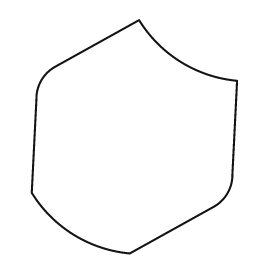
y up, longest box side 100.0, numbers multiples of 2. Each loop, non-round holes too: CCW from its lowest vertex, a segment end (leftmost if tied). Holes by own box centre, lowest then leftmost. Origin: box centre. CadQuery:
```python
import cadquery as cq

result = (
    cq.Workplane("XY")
    .moveTo(-2.0, -50.0)
    .lineTo(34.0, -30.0)
    .threePointArc((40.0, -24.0), (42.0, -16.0))
    .lineTo(44.0, 24.0)
    .threePointArc((20.0, 32.0), (2.0, 50.0))
    .lineTo(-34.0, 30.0)
    .threePointArc((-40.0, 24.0), (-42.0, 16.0))
    .lineTo(-44.0, -24.0)
    .threePointArc((-26.0, -42.0), (-2.0, -50.0))
    .close()
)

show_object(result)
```